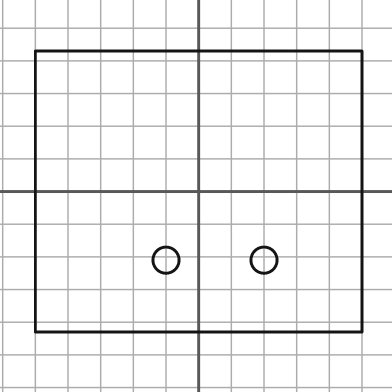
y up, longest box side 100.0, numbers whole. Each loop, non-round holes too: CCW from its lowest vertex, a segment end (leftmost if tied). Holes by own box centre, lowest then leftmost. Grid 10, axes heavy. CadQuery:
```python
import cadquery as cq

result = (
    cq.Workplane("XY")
    .moveTo(-50.0, -43.0)
    .lineTo(50.0, -43.0)
    .lineTo(50.0, 43.0)
    .lineTo(-50.0, 43.0)
    .close()
    .moveTo(-10.0, -21.0)
    .circle(4.0)
    .moveTo(20.0, -21.0)
    .circle(4.0)
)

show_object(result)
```